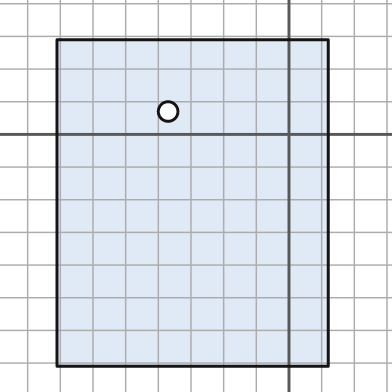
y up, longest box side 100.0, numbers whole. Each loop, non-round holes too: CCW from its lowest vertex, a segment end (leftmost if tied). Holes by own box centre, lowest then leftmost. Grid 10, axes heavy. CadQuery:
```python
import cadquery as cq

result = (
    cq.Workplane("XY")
    .moveTo(-71.0, -71.0)
    .lineTo(12.0, -71.0)
    .lineTo(12.0, 29.0)
    .lineTo(-71.0, 29.0)
    .close()
    .moveTo(-37.0, 7.0)
    .circle(3.0)
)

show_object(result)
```